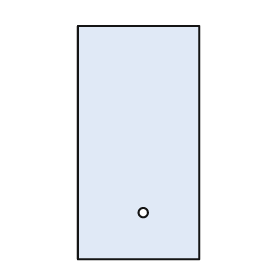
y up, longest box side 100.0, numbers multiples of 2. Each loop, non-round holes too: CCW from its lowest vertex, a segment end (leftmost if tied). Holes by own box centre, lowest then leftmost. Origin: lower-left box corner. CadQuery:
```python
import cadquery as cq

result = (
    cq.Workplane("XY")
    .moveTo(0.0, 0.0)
    .lineTo(52.0, 0.0)
    .lineTo(52.0, 100.0)
    .lineTo(0.0, 100.0)
    .close()
    .moveTo(28.0, 20.0)
    .circle(2.0)
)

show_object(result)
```